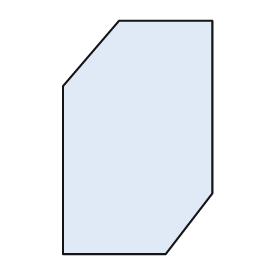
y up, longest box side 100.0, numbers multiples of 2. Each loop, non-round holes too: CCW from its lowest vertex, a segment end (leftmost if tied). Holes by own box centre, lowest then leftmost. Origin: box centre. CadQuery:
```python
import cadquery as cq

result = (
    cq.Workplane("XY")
    .moveTo(-32.0, -50.0)
    .lineTo(12.0, -50.0)
    .lineTo(32.0, -24.0)
    .lineTo(32.0, 50.0)
    .lineTo(-8.0, 50.0)
    .lineTo(-32.0, 22.0)
    .close()
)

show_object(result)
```